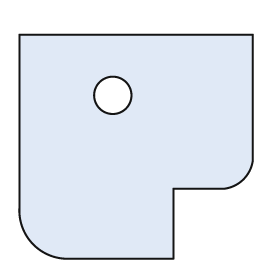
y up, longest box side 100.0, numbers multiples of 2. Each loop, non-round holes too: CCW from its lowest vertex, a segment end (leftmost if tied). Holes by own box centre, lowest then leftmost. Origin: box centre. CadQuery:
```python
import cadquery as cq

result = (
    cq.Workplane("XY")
    .moveTo(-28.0, -48.0)
    .lineTo(16.0, -48.0)
    .lineTo(16.0, -18.0)
    .lineTo(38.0, -18.0)
    .threePointArc((46.0, -14.0), (50.0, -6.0))
    .lineTo(50.0, 48.0)
    .lineTo(-50.0, 48.0)
    .lineTo(-50.0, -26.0)
    .threePointArc((-44.0, -42.0), (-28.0, -48.0))
    .close()
    .moveTo(-10.0, 22.0)
    .circle(8.0)
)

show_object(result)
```